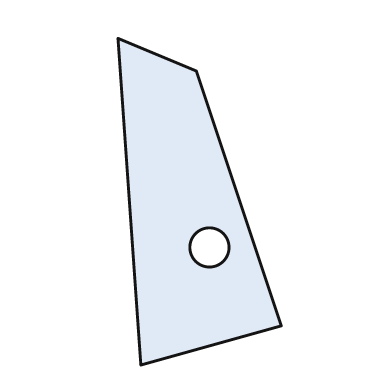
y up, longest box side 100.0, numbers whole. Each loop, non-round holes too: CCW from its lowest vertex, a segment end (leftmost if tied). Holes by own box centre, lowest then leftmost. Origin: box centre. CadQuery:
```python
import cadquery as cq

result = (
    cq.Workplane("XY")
    .moveTo(-18.0, -50.0)
    .lineTo(25.0, -38.0)
    .lineTo(-1.0, 40.0)
    .lineTo(-25.0, 50.0)
    .close()
    .moveTo(3.0, -14.0)
    .circle(6.0)
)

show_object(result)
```